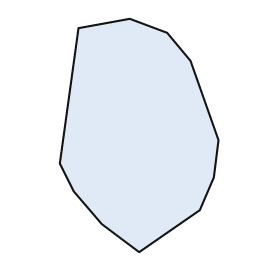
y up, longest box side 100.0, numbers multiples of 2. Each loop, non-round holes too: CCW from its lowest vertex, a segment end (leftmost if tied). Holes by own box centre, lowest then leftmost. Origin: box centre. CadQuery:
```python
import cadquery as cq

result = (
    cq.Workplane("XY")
    .moveTo(0.0, -50.0)
    .lineTo(26.0, -32.0)
    .lineTo(32.0, -18.0)
    .lineTo(34.0, -2.0)
    .lineTo(22.0, 32.0)
    .lineTo(12.0, 44.0)
    .lineTo(-4.0, 50.0)
    .lineTo(-26.0, 46.0)
    .lineTo(-34.0, -12.0)
    .lineTo(-28.0, -24.0)
    .lineTo(-16.0, -38.0)
    .close()
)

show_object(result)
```